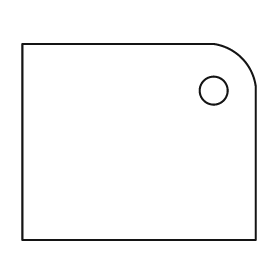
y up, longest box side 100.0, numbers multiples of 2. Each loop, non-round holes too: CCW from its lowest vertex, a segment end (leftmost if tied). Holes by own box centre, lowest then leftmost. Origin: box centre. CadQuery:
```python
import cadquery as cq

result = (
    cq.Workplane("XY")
    .moveTo(-50.0, -42.0)
    .lineTo(50.0, -42.0)
    .lineTo(50.0, 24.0)
    .threePointArc((44.0, 36.0), (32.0, 42.0))
    .lineTo(-50.0, 42.0)
    .close()
    .moveTo(32.0, 22.0)
    .circle(6.0)
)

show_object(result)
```